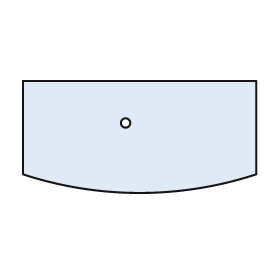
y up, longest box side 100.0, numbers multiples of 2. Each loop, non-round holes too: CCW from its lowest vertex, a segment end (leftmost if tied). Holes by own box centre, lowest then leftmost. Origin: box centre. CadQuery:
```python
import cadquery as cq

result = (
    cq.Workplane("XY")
    .moveTo(-50.0, -16.0)
    .threePointArc((0.0, -24.0), (50.0, -16.0))
    .lineTo(50.0, 24.0)
    .lineTo(-50.0, 24.0)
    .close()
    .moveTo(-6.0, 6.0)
    .circle(2.0)
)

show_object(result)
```